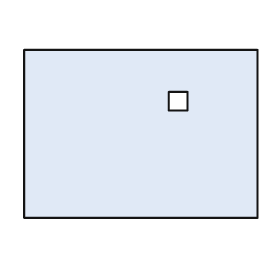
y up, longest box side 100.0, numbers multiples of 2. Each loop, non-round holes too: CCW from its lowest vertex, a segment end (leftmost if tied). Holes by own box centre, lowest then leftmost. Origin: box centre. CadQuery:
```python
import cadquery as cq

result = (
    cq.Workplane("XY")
    .moveTo(-50.0, -36.0)
    .lineTo(50.0, -36.0)
    .lineTo(50.0, 36.0)
    .lineTo(-50.0, 36.0)
    .close()
    .moveTo(12.0, 10.0)
    .lineTo(20.0, 10.0)
    .lineTo(20.0, 18.0)
    .lineTo(12.0, 18.0)
    .close()
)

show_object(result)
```